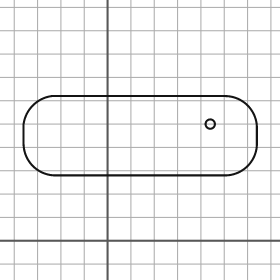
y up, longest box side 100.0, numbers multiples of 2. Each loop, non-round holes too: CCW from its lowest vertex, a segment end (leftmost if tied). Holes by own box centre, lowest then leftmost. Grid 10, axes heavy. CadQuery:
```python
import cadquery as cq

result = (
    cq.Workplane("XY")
    .moveTo(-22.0, 28.0)
    .lineTo(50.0, 28.0)
    .threePointArc((60.0, 32.0), (64.0, 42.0))
    .lineTo(64.0, 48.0)
    .threePointArc((60.0, 58.0), (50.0, 62.0))
    .lineTo(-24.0, 62.0)
    .threePointArc((-32.0, 58.0), (-36.0, 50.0))
    .lineTo(-36.0, 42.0)
    .threePointArc((-32.0, 32.0), (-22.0, 28.0))
    .close()
    .moveTo(44.0, 50.0)
    .circle(2.0)
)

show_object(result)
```